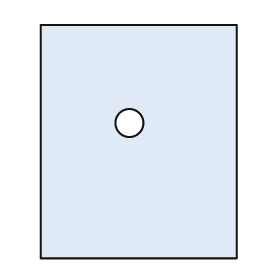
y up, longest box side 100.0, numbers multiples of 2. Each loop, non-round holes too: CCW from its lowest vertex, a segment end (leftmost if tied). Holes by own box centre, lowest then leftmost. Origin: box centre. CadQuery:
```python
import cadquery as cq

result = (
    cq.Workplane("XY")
    .moveTo(-42.0, -50.0)
    .lineTo(42.0, -50.0)
    .lineTo(42.0, 50.0)
    .lineTo(-42.0, 50.0)
    .close()
    .moveTo(-4.0, 8.0)
    .circle(6.0)
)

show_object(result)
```